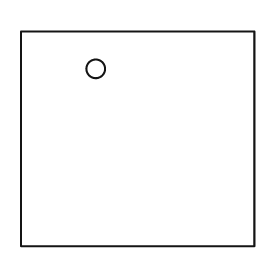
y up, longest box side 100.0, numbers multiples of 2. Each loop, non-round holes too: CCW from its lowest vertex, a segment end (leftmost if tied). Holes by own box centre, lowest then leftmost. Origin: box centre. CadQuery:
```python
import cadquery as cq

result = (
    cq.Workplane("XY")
    .moveTo(-50.0, -46.0)
    .lineTo(50.0, -46.0)
    .lineTo(50.0, 46.0)
    .lineTo(-50.0, 46.0)
    .close()
    .moveTo(-18.0, 30.0)
    .circle(4.0)
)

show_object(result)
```